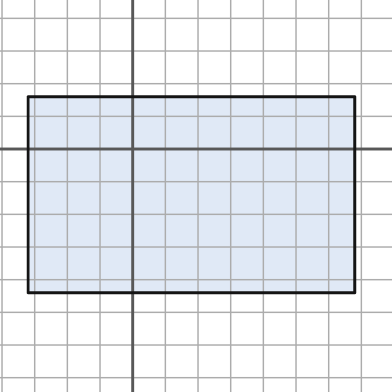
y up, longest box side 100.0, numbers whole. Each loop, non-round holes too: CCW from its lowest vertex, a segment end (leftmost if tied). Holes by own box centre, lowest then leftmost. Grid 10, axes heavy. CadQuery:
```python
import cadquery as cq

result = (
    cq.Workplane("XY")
    .moveTo(-32.0, -44.0)
    .lineTo(68.0, -44.0)
    .lineTo(68.0, 16.0)
    .lineTo(-32.0, 16.0)
    .close()
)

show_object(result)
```